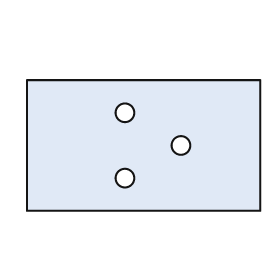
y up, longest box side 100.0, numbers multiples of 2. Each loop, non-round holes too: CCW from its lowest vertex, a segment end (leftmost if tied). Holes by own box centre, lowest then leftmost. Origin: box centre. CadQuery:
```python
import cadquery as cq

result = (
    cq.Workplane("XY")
    .moveTo(-50.0, -28.0)
    .lineTo(50.0, -28.0)
    .lineTo(50.0, 28.0)
    .lineTo(-50.0, 28.0)
    .close()
    .moveTo(-8.0, -14.0)
    .circle(4.0)
    .moveTo(16.0, 0.0)
    .circle(4.0)
    .moveTo(-8.0, 14.0)
    .circle(4.0)
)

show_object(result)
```